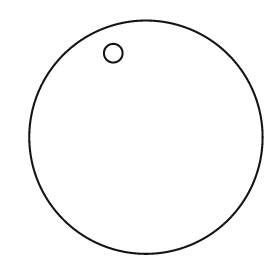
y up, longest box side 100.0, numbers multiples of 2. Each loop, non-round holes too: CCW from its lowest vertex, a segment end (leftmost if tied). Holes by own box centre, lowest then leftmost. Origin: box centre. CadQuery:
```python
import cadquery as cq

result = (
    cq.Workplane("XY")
    .moveTo(0.0, 0.0)
    .circle(50.0)
    .moveTo(-14.0, 36.0)
    .circle(4.0)
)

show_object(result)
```